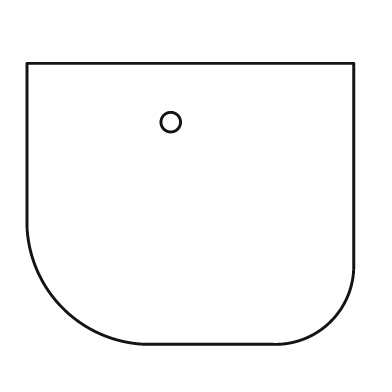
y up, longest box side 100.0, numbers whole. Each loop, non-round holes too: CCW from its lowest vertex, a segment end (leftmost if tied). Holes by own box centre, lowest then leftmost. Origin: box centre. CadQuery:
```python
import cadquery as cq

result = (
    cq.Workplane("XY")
    .moveTo(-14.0, -43.0)
    .lineTo(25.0, -43.0)
    .threePointArc((43.0, -36.0), (50.0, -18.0))
    .lineTo(50.0, 43.0)
    .lineTo(-50.0, 43.0)
    .lineTo(-50.0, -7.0)
    .threePointArc((-39.0, -32.0), (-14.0, -43.0))
    .close()
    .moveTo(-6.0, 25.0)
    .circle(3.0)
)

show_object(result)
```